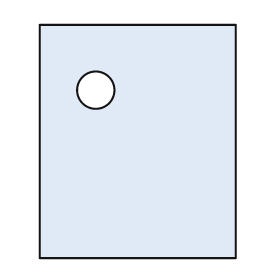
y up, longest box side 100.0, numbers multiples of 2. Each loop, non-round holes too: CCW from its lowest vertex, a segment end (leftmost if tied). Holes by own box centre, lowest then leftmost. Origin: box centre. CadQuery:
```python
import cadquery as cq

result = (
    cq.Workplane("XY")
    .moveTo(-42.0, -50.0)
    .lineTo(42.0, -50.0)
    .lineTo(42.0, 50.0)
    .lineTo(-42.0, 50.0)
    .close()
    .moveTo(-18.0, 22.0)
    .circle(8.0)
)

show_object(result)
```